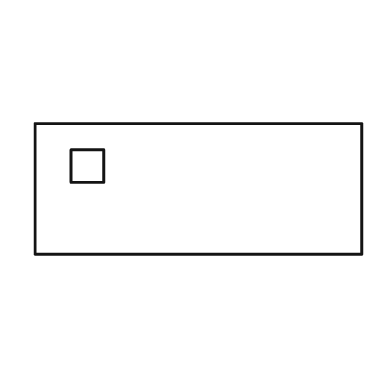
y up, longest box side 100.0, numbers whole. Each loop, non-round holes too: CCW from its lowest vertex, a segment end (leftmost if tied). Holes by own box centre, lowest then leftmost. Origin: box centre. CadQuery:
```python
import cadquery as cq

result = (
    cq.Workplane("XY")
    .moveTo(-50.0, -20.0)
    .lineTo(50.0, -20.0)
    .lineTo(50.0, 20.0)
    .lineTo(-50.0, 20.0)
    .close()
    .moveTo(-39.0, 2.0)
    .lineTo(-29.0, 2.0)
    .lineTo(-29.0, 12.0)
    .lineTo(-39.0, 12.0)
    .close()
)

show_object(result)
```